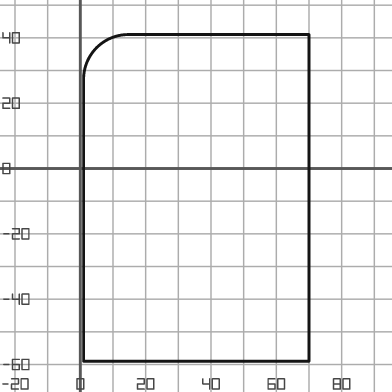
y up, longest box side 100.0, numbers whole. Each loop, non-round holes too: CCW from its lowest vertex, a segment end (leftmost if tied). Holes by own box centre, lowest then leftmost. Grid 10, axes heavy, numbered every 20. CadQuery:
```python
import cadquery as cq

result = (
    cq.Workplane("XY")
    .moveTo(1.0, -59.0)
    .lineTo(70.0, -59.0)
    .lineTo(70.0, 41.0)
    .lineTo(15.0, 41.0)
    .threePointArc((5.0, 37.0), (1.0, 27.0))
    .close()
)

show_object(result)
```